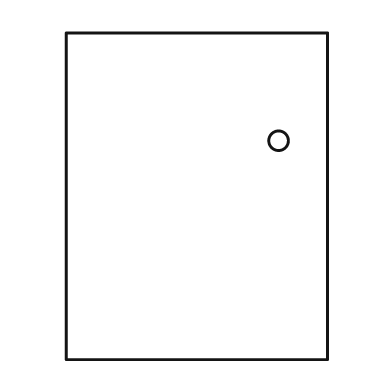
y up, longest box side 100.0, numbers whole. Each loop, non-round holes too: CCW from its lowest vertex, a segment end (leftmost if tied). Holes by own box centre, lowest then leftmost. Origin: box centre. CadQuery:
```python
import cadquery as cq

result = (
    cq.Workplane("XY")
    .moveTo(-40.0, -50.0)
    .lineTo(40.0, -50.0)
    .lineTo(40.0, 50.0)
    .lineTo(-40.0, 50.0)
    .close()
    .moveTo(25.0, 17.0)
    .circle(3.0)
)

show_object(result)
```